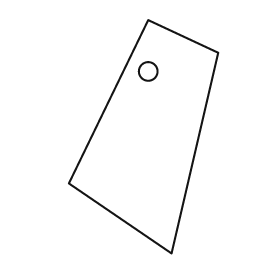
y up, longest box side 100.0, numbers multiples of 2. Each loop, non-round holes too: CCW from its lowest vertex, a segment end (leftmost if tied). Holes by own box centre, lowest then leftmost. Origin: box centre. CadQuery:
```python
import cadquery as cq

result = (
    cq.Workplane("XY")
    .moveTo(12.0, -50.0)
    .lineTo(32.0, 36.0)
    .lineTo(2.0, 50.0)
    .lineTo(-32.0, -20.0)
    .close()
    .moveTo(2.0, 28.0)
    .circle(4.0)
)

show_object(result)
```